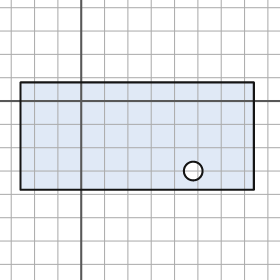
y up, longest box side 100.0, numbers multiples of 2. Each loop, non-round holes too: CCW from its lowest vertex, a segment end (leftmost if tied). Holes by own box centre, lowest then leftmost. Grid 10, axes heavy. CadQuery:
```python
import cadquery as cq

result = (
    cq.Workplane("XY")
    .moveTo(-26.0, -38.0)
    .lineTo(74.0, -38.0)
    .lineTo(74.0, 8.0)
    .lineTo(-26.0, 8.0)
    .close()
    .moveTo(48.0, -30.0)
    .circle(4.0)
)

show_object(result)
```